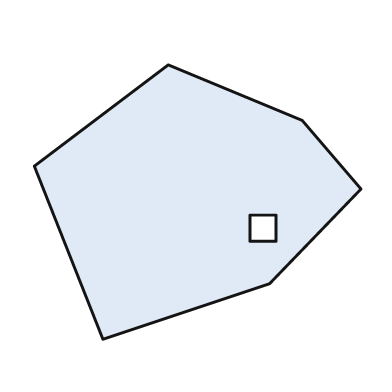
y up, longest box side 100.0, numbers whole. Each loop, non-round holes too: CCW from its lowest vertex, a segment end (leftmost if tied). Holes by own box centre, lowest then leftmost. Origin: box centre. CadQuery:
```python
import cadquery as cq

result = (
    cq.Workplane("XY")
    .moveTo(-29.0, -42.0)
    .lineTo(22.0, -25.0)
    .lineTo(50.0, 4.0)
    .lineTo(32.0, 25.0)
    .lineTo(-9.0, 42.0)
    .lineTo(-50.0, 11.0)
    .close()
    .moveTo(16.0, -12.0)
    .lineTo(24.0, -12.0)
    .lineTo(24.0, -4.0)
    .lineTo(16.0, -4.0)
    .close()
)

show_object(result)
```